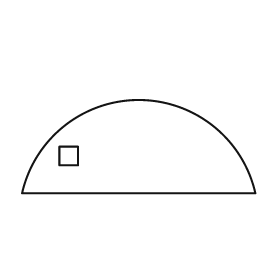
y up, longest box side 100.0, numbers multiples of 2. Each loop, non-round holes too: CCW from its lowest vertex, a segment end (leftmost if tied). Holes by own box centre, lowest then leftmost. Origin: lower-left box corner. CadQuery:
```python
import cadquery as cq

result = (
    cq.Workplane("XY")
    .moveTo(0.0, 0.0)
    .lineTo(100.0, 0.0)
    .threePointArc((50.0, 40.0), (0.0, 0.0))
    .close()
    .moveTo(16.0, 12.0)
    .lineTo(24.0, 12.0)
    .lineTo(24.0, 20.0)
    .lineTo(16.0, 20.0)
    .close()
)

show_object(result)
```